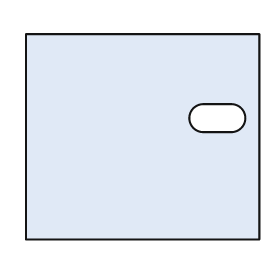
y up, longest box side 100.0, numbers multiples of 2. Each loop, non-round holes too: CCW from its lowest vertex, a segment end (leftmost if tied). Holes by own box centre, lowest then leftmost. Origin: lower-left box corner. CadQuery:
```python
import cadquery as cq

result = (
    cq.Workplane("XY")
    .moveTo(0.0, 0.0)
    .lineTo(100.0, 0.0)
    .lineTo(100.0, 88.0)
    .lineTo(0.0, 88.0)
    .close()
    .moveTo(76.0, 46.0)
    .lineTo(88.0, 46.0)
    .threePointArc((94.0, 52.0), (88.0, 58.0))
    .lineTo(76.0, 58.0)
    .threePointArc((70.0, 52.0), (76.0, 46.0))
    .close()
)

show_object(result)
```